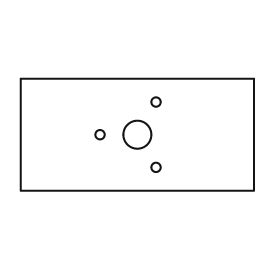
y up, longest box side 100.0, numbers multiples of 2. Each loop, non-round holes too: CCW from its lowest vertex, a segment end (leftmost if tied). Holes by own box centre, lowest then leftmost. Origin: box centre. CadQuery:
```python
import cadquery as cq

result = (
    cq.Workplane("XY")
    .moveTo(-50.0, -24.0)
    .lineTo(50.0, -24.0)
    .lineTo(50.0, 24.0)
    .lineTo(-50.0, 24.0)
    .close()
    .moveTo(8.0, -14.0)
    .circle(2.0)
    .moveTo(-16.0, 0.0)
    .circle(2.0)
    .moveTo(0.0, 0.0)
    .circle(6.0)
    .moveTo(8.0, 14.0)
    .circle(2.0)
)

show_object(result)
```